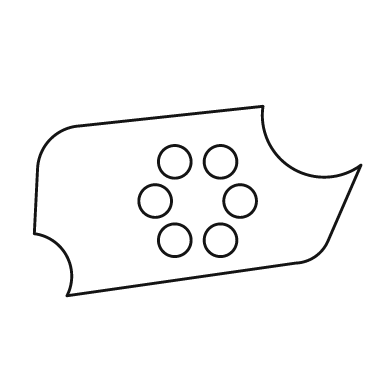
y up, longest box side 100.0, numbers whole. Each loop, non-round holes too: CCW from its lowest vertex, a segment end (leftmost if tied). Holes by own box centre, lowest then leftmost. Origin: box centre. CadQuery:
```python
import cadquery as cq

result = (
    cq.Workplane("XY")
    .moveTo(-40.0, -29.0)
    .lineTo(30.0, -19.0)
    .threePointArc((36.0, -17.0), (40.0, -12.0))
    .lineTo(50.0, 11.0)
    .threePointArc((29.0, 10.0), (20.0, 29.0))
    .lineTo(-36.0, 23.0)
    .threePointArc((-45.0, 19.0), (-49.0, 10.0))
    .lineTo(-50.0, -10.0)
    .threePointArc((-40.0, -17.0), (-40.0, -29.0))
    .close()
    .moveTo(-7.0, -12.0)
    .circle(5.0)
    .moveTo(7.0, -12.0)
    .circle(5.0)
    .moveTo(-13.0, 0.0)
    .circle(5.0)
    .moveTo(13.0, 0.0)
    .circle(5.0)
    .moveTo(-7.0, 12.0)
    .circle(5.0)
    .moveTo(7.0, 12.0)
    .circle(5.0)
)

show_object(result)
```